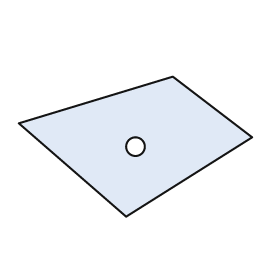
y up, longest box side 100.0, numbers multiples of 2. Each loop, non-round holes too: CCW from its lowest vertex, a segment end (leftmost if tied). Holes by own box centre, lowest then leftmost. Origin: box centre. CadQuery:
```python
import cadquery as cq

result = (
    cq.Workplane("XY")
    .moveTo(-4.0, -30.0)
    .lineTo(50.0, 4.0)
    .lineTo(16.0, 30.0)
    .lineTo(-50.0, 10.0)
    .close()
    .moveTo(0.0, 0.0)
    .circle(4.0)
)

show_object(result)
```